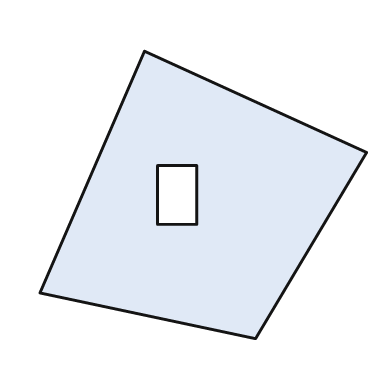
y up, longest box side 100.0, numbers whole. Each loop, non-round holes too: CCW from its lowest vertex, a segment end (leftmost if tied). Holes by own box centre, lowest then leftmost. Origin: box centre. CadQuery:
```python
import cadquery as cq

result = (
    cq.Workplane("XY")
    .moveTo(16.0, -44.0)
    .lineTo(50.0, 13.0)
    .lineTo(-18.0, 44.0)
    .lineTo(-50.0, -30.0)
    .close()
    .moveTo(-14.0, -9.0)
    .lineTo(-2.0, -9.0)
    .lineTo(-2.0, 9.0)
    .lineTo(-14.0, 9.0)
    .close()
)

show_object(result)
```